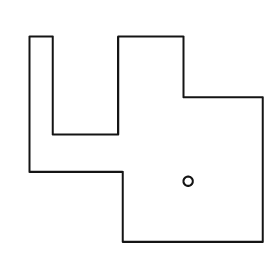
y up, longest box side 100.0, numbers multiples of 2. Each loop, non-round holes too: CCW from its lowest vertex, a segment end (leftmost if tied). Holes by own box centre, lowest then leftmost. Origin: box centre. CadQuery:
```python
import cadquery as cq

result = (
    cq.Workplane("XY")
    .moveTo(-10.0, -44.0)
    .lineTo(50.0, -44.0)
    .lineTo(50.0, 18.0)
    .lineTo(16.0, 18.0)
    .lineTo(16.0, 44.0)
    .lineTo(-12.0, 44.0)
    .lineTo(-12.0, 2.0)
    .lineTo(-40.0, 2.0)
    .lineTo(-40.0, 44.0)
    .lineTo(-50.0, 44.0)
    .lineTo(-50.0, -14.0)
    .lineTo(-10.0, -14.0)
    .close()
    .moveTo(18.0, -18.0)
    .circle(2.0)
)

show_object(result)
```